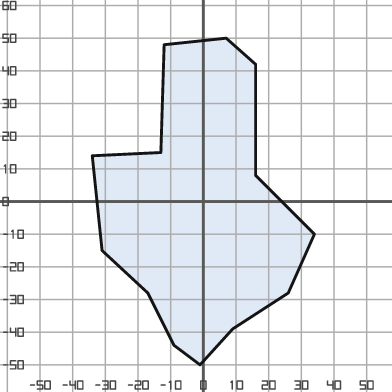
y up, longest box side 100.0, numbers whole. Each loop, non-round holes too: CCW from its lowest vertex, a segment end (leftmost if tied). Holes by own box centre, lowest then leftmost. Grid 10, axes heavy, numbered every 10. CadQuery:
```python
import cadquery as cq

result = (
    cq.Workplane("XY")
    .moveTo(-1.0, -50.0)
    .lineTo(9.0, -39.0)
    .lineTo(26.0, -28.0)
    .lineTo(34.0, -10.0)
    .lineTo(16.0, 8.0)
    .lineTo(16.0, 42.0)
    .lineTo(7.0, 50.0)
    .lineTo(-12.0, 48.0)
    .lineTo(-13.0, 15.0)
    .lineTo(-34.0, 14.0)
    .lineTo(-31.0, -15.0)
    .lineTo(-17.0, -28.0)
    .lineTo(-9.0, -44.0)
    .close()
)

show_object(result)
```